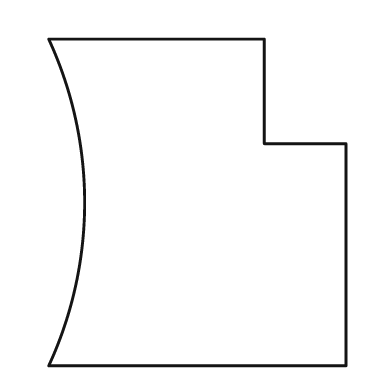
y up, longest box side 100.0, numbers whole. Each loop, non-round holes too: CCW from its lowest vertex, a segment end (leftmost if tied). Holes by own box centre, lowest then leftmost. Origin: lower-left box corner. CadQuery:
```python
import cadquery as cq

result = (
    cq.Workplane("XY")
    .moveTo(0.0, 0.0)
    .lineTo(91.0, 0.0)
    .lineTo(91.0, 68.0)
    .lineTo(66.0, 68.0)
    .lineTo(66.0, 100.0)
    .lineTo(0.0, 100.0)
    .threePointArc((11.0, 50.0), (0.0, 0.0))
    .close()
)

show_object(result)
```